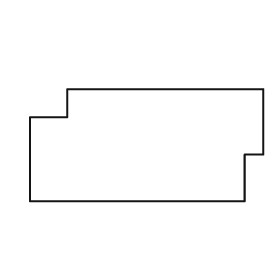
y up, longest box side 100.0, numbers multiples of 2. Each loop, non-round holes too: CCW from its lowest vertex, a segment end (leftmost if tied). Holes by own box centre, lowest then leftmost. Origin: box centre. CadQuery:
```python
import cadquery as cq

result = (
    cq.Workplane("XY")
    .moveTo(-50.0, -24.0)
    .lineTo(42.0, -24.0)
    .lineTo(42.0, -4.0)
    .lineTo(50.0, -4.0)
    .lineTo(50.0, 24.0)
    .lineTo(-34.0, 24.0)
    .lineTo(-34.0, 12.0)
    .lineTo(-50.0, 12.0)
    .close()
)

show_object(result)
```